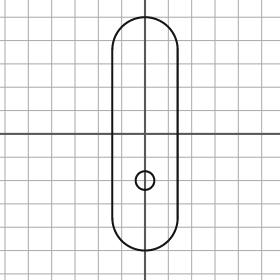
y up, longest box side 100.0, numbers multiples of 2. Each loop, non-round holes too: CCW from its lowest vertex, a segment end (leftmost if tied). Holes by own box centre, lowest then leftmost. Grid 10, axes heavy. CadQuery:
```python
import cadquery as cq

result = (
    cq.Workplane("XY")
    .moveTo(-14.0, -36.0)
    .threePointArc((0.0, -50.0), (14.0, -36.0))
    .lineTo(14.0, 36.0)
    .threePointArc((0.0, 50.0), (-14.0, 36.0))
    .close()
    .moveTo(0.0, -20.0)
    .circle(4.0)
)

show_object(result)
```